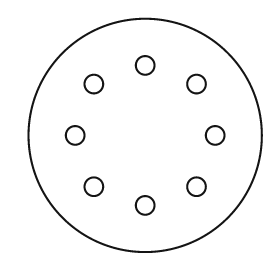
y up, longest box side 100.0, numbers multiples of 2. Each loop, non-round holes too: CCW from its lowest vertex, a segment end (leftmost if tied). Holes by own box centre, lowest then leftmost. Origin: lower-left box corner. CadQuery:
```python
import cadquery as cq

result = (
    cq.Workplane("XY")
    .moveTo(50.0, 50.0)
    .circle(50.0)
    .moveTo(50.0, 20.0)
    .circle(4.0)
    .moveTo(28.0, 28.0)
    .circle(4.0)
    .moveTo(72.0, 28.0)
    .circle(4.0)
    .moveTo(20.0, 50.0)
    .circle(4.0)
    .moveTo(80.0, 50.0)
    .circle(4.0)
    .moveTo(28.0, 72.0)
    .circle(4.0)
    .moveTo(72.0, 72.0)
    .circle(4.0)
    .moveTo(50.0, 80.0)
    .circle(4.0)
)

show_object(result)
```